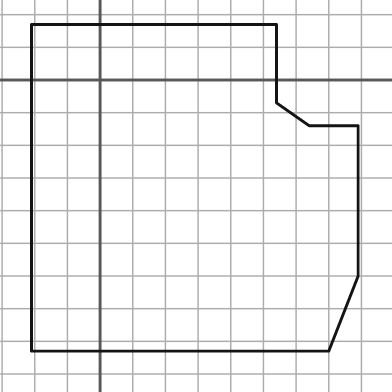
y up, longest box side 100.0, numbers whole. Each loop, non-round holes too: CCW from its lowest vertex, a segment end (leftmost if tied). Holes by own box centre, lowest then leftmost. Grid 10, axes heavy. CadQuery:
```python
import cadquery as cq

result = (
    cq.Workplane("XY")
    .moveTo(-21.0, -83.0)
    .lineTo(70.0, -83.0)
    .lineTo(79.0, -60.0)
    .lineTo(79.0, -14.0)
    .lineTo(64.0, -14.0)
    .lineTo(54.0, -7.0)
    .lineTo(54.0, 17.0)
    .lineTo(-21.0, 17.0)
    .close()
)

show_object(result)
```